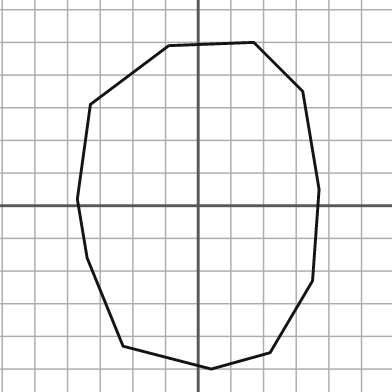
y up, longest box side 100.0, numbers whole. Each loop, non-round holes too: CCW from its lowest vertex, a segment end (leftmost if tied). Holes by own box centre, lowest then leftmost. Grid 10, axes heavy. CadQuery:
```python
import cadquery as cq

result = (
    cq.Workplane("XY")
    .moveTo(4.0, -50.0)
    .lineTo(22.0, -45.0)
    .lineTo(35.0, -23.0)
    .lineTo(37.0, 5.0)
    .lineTo(32.0, 35.0)
    .lineTo(17.0, 50.0)
    .lineTo(-9.0, 49.0)
    .lineTo(-33.0, 31.0)
    .lineTo(-37.0, 2.0)
    .lineTo(-34.0, -16.0)
    .lineTo(-23.0, -43.0)
    .close()
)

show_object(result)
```